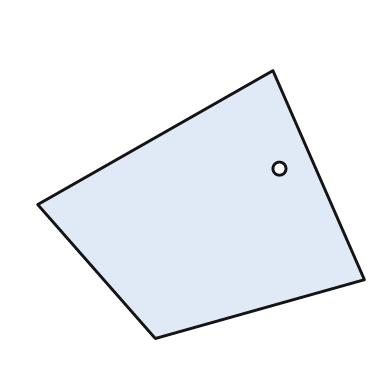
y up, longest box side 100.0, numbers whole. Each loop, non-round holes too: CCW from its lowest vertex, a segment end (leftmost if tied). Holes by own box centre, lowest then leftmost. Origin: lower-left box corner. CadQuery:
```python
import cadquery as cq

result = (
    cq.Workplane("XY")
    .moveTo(36.0, 0.0)
    .lineTo(100.0, 18.0)
    .lineTo(72.0, 82.0)
    .lineTo(0.0, 41.0)
    .close()
    .moveTo(74.0, 52.0)
    .circle(2.0)
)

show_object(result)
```